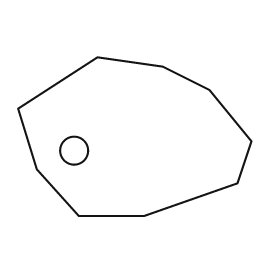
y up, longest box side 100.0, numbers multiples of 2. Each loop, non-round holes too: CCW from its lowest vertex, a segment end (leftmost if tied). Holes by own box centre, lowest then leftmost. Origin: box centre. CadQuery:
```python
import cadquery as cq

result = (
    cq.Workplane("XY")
    .moveTo(-24.0, -34.0)
    .lineTo(4.0, -34.0)
    .lineTo(44.0, -20.0)
    .lineTo(50.0, -2.0)
    .lineTo(32.0, 20.0)
    .lineTo(12.0, 30.0)
    .lineTo(-16.0, 34.0)
    .lineTo(-50.0, 12.0)
    .lineTo(-42.0, -14.0)
    .close()
    .moveTo(-26.0, -6.0)
    .circle(6.0)
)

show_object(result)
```